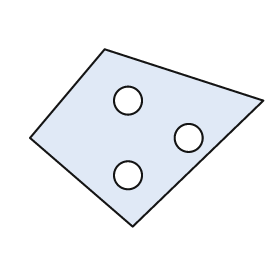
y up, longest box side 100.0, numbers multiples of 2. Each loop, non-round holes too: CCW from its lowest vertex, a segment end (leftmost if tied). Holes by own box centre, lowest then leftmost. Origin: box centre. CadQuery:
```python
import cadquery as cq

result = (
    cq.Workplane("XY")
    .moveTo(-6.0, -38.0)
    .lineTo(50.0, 16.0)
    .lineTo(-18.0, 38.0)
    .lineTo(-50.0, 0.0)
    .close()
    .moveTo(-8.0, -16.0)
    .circle(6.0)
    .moveTo(18.0, 0.0)
    .circle(6.0)
    .moveTo(-8.0, 16.0)
    .circle(6.0)
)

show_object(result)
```